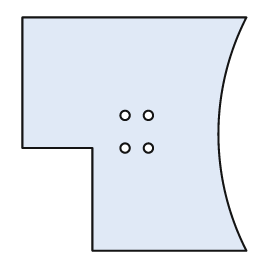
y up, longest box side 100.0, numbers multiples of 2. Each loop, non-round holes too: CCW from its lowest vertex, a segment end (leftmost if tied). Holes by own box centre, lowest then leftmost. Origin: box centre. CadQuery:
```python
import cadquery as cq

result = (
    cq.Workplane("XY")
    .moveTo(-18.0, -50.0)
    .lineTo(48.0, -50.0)
    .threePointArc((36.0, 0.0), (48.0, 50.0))
    .lineTo(-48.0, 50.0)
    .lineTo(-48.0, -6.0)
    .lineTo(-18.0, -6.0)
    .close()
    .moveTo(-4.0, -6.0)
    .circle(2.0)
    .moveTo(6.0, -6.0)
    .circle(2.0)
    .moveTo(-4.0, 8.0)
    .circle(2.0)
    .moveTo(6.0, 8.0)
    .circle(2.0)
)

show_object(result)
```